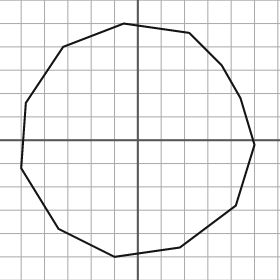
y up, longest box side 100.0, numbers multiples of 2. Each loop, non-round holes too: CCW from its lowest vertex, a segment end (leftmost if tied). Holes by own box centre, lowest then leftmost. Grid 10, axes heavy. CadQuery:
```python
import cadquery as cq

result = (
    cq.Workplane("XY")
    .moveTo(-10.0, -50.0)
    .lineTo(18.0, -46.0)
    .lineTo(42.0, -28.0)
    .lineTo(50.0, -2.0)
    .lineTo(44.0, 18.0)
    .lineTo(36.0, 32.0)
    .lineTo(22.0, 46.0)
    .lineTo(-6.0, 50.0)
    .lineTo(-32.0, 40.0)
    .lineTo(-48.0, 16.0)
    .lineTo(-50.0, -12.0)
    .lineTo(-34.0, -38.0)
    .close()
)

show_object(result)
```